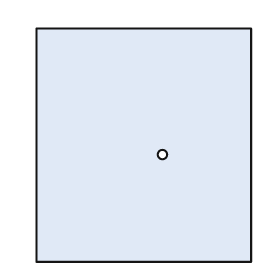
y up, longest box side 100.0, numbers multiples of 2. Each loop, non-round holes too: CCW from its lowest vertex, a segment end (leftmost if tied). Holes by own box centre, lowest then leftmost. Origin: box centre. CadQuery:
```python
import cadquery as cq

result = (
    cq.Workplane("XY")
    .moveTo(-46.0, -50.0)
    .lineTo(46.0, -50.0)
    .lineTo(46.0, 50.0)
    .lineTo(-46.0, 50.0)
    .close()
    .moveTo(8.0, -4.0)
    .circle(2.0)
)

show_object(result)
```